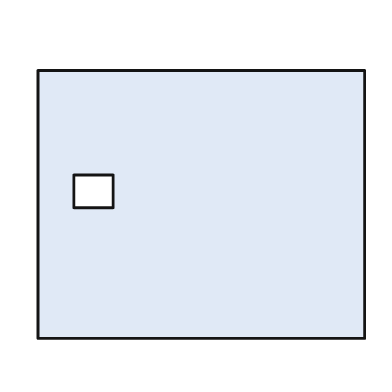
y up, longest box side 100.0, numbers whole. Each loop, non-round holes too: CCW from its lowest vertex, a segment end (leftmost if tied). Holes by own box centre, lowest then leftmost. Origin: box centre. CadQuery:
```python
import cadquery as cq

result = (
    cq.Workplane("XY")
    .moveTo(-50.0, -41.0)
    .lineTo(50.0, -41.0)
    .lineTo(50.0, 41.0)
    .lineTo(-50.0, 41.0)
    .close()
    .moveTo(-39.0, -1.0)
    .lineTo(-27.0, -1.0)
    .lineTo(-27.0, 9.0)
    .lineTo(-39.0, 9.0)
    .close()
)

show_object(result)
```